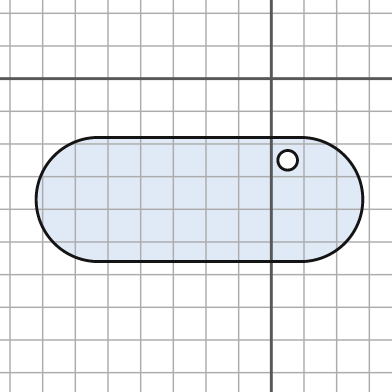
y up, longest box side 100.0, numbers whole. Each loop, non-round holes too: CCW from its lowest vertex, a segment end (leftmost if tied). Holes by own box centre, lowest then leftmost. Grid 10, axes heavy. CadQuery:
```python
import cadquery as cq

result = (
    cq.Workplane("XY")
    .moveTo(-53.0, -56.0)
    .lineTo(9.0, -56.0)
    .threePointArc((28.0, -37.0), (9.0, -18.0))
    .lineTo(-53.0, -18.0)
    .threePointArc((-72.0, -37.0), (-53.0, -56.0))
    .close()
    .moveTo(5.0, -25.0)
    .circle(3.0)
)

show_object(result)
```